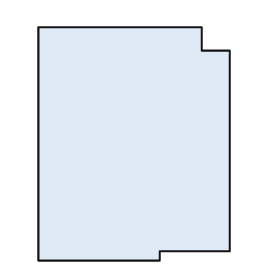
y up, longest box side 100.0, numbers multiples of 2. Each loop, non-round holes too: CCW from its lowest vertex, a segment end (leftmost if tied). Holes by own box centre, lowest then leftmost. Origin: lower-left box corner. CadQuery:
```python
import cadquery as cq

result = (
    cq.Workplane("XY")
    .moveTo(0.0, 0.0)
    .lineTo(52.0, 0.0)
    .lineTo(52.0, 4.0)
    .lineTo(82.0, 4.0)
    .lineTo(82.0, 90.0)
    .lineTo(70.0, 90.0)
    .lineTo(70.0, 100.0)
    .lineTo(0.0, 100.0)
    .close()
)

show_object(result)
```